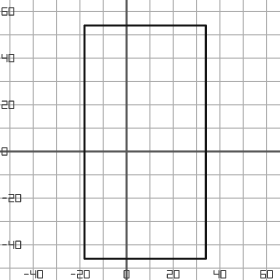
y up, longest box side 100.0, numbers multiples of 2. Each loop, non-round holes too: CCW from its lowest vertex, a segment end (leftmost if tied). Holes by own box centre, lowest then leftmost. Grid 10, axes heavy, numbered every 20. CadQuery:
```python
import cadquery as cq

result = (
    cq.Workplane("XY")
    .moveTo(-18.0, -46.0)
    .lineTo(34.0, -46.0)
    .lineTo(34.0, 54.0)
    .lineTo(-18.0, 54.0)
    .close()
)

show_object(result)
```